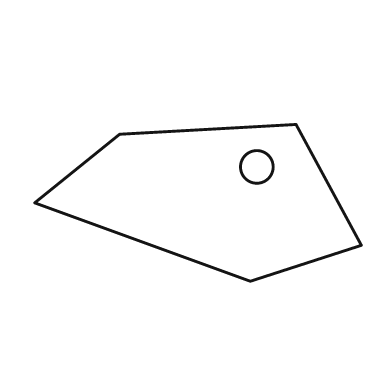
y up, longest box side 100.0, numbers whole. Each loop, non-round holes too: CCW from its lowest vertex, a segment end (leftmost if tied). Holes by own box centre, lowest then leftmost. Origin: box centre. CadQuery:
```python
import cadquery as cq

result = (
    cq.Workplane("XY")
    .moveTo(16.0, -24.0)
    .lineTo(50.0, -13.0)
    .lineTo(30.0, 24.0)
    .lineTo(-24.0, 21.0)
    .lineTo(-50.0, 0.0)
    .close()
    .moveTo(18.0, 11.0)
    .circle(5.0)
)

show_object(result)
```